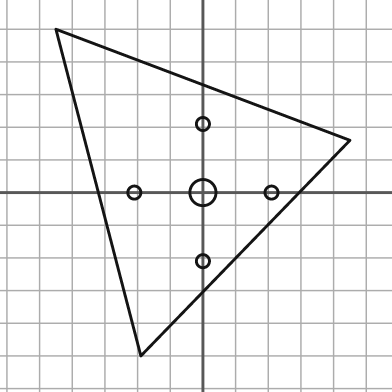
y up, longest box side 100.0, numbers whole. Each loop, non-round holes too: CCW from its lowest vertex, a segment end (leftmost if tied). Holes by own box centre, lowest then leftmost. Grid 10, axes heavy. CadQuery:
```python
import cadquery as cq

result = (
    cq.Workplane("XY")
    .moveTo(-19.0, -50.0)
    .lineTo(45.0, 16.0)
    .lineTo(-45.0, 50.0)
    .close()
    .moveTo(0.0, -21.0)
    .circle(2.0)
    .moveTo(-21.0, 0.0)
    .circle(2.0)
    .moveTo(0.0, 0.0)
    .circle(4.0)
    .moveTo(21.0, 0.0)
    .circle(2.0)
    .moveTo(0.0, 21.0)
    .circle(2.0)
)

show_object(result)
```